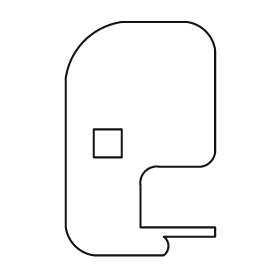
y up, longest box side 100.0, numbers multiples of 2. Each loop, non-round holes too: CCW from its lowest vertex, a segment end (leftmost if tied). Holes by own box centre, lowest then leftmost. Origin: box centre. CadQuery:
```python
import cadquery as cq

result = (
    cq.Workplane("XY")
    .moveTo(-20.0, -50.0)
    .lineTo(10.0, -50.0)
    .threePointArc((12.0, -46.0), (10.0, -42.0))
    .lineTo(32.0, -42.0)
    .lineTo(32.0, -38.0)
    .lineTo(0.0, -38.0)
    .lineTo(0.0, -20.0)
    .threePointArc((2.0, -14.0), (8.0, -12.0))
    .lineTo(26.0, -12.0)
    .threePointArc((30.0, -10.0), (32.0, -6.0))
    .lineTo(32.0, 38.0)
    .threePointArc((28.0, 46.0), (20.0, 50.0))
    .lineTo(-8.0, 50.0)
    .threePointArc((-24.0, 42.0), (-32.0, 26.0))
    .lineTo(-32.0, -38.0)
    .threePointArc((-28.0, -46.0), (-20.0, -50.0))
    .close()
    .moveTo(-20.0, -8.0)
    .lineTo(-8.0, -8.0)
    .lineTo(-8.0, 4.0)
    .lineTo(-20.0, 4.0)
    .close()
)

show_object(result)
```